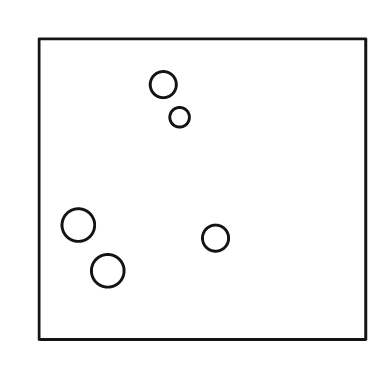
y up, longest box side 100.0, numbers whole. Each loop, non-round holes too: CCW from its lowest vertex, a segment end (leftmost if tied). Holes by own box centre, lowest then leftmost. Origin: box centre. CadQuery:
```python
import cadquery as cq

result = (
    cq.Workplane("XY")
    .moveTo(-50.0, -46.0)
    .lineTo(50.0, -46.0)
    .lineTo(50.0, 46.0)
    .lineTo(-50.0, 46.0)
    .close()
    .moveTo(-29.0, -25.0)
    .circle(5.0)
    .moveTo(4.0, -15.0)
    .circle(4.0)
    .moveTo(-38.0, -11.0)
    .circle(5.0)
    .moveTo(-7.0, 22.0)
    .circle(3.0)
    .moveTo(-12.0, 32.0)
    .circle(4.0)
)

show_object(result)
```